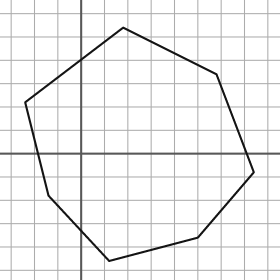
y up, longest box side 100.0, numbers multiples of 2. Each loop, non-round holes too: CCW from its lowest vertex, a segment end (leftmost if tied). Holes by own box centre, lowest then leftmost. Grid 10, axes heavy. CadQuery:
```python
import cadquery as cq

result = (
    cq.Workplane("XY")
    .moveTo(12.0, -46.0)
    .lineTo(50.0, -36.0)
    .lineTo(74.0, -8.0)
    .lineTo(58.0, 34.0)
    .lineTo(18.0, 54.0)
    .lineTo(-24.0, 22.0)
    .lineTo(-14.0, -18.0)
    .close()
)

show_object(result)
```